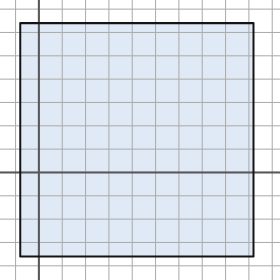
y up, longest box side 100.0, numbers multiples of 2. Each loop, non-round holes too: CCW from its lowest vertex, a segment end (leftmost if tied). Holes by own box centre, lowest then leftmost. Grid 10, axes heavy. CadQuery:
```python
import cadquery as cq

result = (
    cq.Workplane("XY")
    .moveTo(-8.0, -36.0)
    .lineTo(92.0, -36.0)
    .lineTo(92.0, 64.0)
    .lineTo(-8.0, 64.0)
    .close()
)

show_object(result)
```